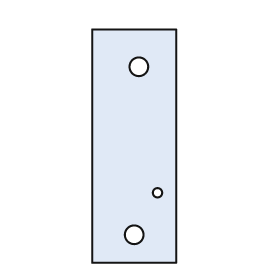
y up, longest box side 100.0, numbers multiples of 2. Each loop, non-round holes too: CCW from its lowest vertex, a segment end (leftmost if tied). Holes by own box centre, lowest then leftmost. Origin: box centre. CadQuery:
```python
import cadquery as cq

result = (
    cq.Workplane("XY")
    .moveTo(-18.0, -50.0)
    .lineTo(18.0, -50.0)
    .lineTo(18.0, 50.0)
    .lineTo(-18.0, 50.0)
    .close()
    .moveTo(0.0, -38.0)
    .circle(4.0)
    .moveTo(10.0, -20.0)
    .circle(2.0)
    .moveTo(2.0, 34.0)
    .circle(4.0)
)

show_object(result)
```